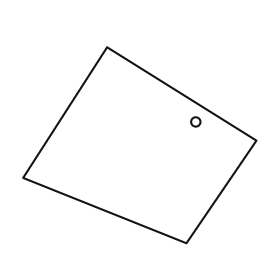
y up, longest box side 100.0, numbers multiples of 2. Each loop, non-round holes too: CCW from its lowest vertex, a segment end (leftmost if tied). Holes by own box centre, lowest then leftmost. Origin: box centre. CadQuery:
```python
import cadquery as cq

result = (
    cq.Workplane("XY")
    .moveTo(20.0, -42.0)
    .lineTo(50.0, 2.0)
    .lineTo(-14.0, 42.0)
    .lineTo(-50.0, -14.0)
    .close()
    .moveTo(24.0, 10.0)
    .circle(2.0)
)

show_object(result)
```